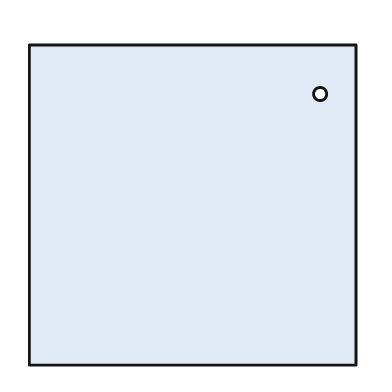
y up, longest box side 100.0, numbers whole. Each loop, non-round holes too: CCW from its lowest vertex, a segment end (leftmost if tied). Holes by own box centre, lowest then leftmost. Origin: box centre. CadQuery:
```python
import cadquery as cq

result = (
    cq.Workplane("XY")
    .moveTo(-50.0, -49.0)
    .lineTo(50.0, -49.0)
    .lineTo(50.0, 49.0)
    .lineTo(-50.0, 49.0)
    .close()
    .moveTo(39.0, 34.0)
    .circle(2.0)
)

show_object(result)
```